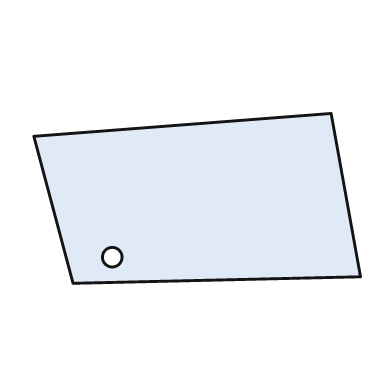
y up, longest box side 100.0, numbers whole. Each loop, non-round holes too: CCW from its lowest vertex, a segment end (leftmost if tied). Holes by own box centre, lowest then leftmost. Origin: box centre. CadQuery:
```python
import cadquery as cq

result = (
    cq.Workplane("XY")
    .moveTo(-38.0, -26.0)
    .lineTo(50.0, -24.0)
    .lineTo(41.0, 26.0)
    .lineTo(-50.0, 19.0)
    .close()
    .moveTo(-26.0, -18.0)
    .circle(3.0)
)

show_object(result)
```